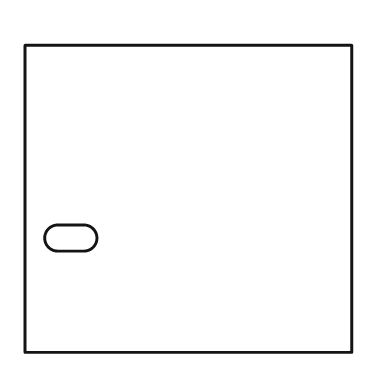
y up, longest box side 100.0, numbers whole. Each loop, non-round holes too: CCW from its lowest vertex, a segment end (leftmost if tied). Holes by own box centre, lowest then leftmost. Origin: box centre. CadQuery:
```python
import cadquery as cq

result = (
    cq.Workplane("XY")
    .moveTo(-50.0, -47.0)
    .lineTo(50.0, -47.0)
    .lineTo(50.0, 47.0)
    .lineTo(-50.0, 47.0)
    .close()
    .moveTo(-40.0, -16.0)
    .lineTo(-32.0, -16.0)
    .threePointArc((-28.0, -12.0), (-32.0, -8.0))
    .lineTo(-40.0, -8.0)
    .threePointArc((-44.0, -12.0), (-40.0, -16.0))
    .close()
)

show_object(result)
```